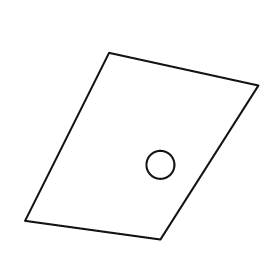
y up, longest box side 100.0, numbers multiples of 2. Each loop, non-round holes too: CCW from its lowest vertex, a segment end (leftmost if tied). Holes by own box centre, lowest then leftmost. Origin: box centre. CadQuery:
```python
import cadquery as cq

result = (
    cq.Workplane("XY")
    .moveTo(8.0, -40.0)
    .lineTo(50.0, 26.0)
    .lineTo(-14.0, 40.0)
    .lineTo(-50.0, -32.0)
    .close()
    .moveTo(8.0, -8.0)
    .circle(6.0)
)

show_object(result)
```